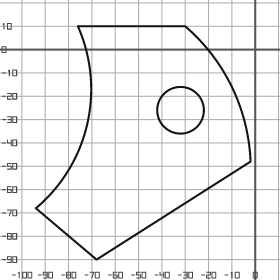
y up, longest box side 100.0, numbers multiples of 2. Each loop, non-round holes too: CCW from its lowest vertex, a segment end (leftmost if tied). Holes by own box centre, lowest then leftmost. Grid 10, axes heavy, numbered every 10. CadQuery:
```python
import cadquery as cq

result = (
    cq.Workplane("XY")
    .moveTo(-68.0, -90.0)
    .lineTo(-2.0, -48.0)
    .threePointArc((-10.0, -16.0), (-30.0, 10.0))
    .lineTo(-76.0, 10.0)
    .threePointArc((-72.0, -32.0), (-94.0, -68.0))
    .close()
    .moveTo(-32.0, -26.0)
    .circle(10.0)
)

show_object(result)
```